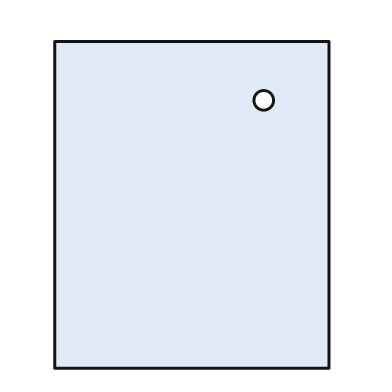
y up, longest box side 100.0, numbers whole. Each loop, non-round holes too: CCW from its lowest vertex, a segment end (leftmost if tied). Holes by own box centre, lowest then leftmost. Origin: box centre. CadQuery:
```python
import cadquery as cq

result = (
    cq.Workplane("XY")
    .moveTo(-42.0, -50.0)
    .lineTo(42.0, -50.0)
    .lineTo(42.0, 50.0)
    .lineTo(-42.0, 50.0)
    .close()
    .moveTo(22.0, 32.0)
    .circle(3.0)
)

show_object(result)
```